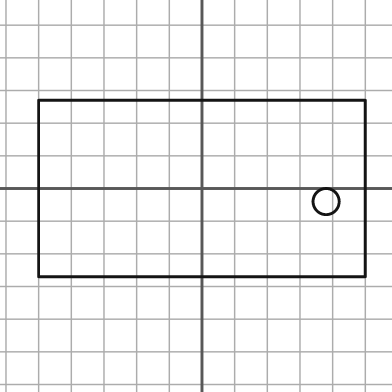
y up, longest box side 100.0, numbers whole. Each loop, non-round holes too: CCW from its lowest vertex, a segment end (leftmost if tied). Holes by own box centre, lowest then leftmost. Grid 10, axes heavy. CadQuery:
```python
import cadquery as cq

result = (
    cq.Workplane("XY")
    .moveTo(-50.0, -27.0)
    .lineTo(50.0, -27.0)
    .lineTo(50.0, 27.0)
    .lineTo(-50.0, 27.0)
    .close()
    .moveTo(38.0, -4.0)
    .circle(4.0)
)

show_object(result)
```